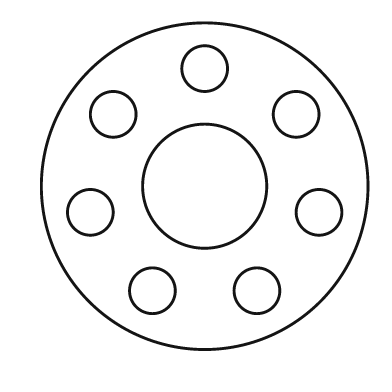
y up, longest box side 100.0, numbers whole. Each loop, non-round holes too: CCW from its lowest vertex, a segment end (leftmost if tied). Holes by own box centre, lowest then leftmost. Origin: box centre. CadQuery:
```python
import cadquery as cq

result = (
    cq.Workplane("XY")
    .moveTo(0.0, 0.0)
    .circle(50.0)
    .moveTo(-16.0, -32.0)
    .circle(7.0)
    .moveTo(16.0, -32.0)
    .circle(7.0)
    .moveTo(-35.0, -8.0)
    .circle(7.0)
    .moveTo(35.0, -8.0)
    .circle(7.0)
    .moveTo(0.0, 0.0)
    .circle(19.0)
    .moveTo(-28.0, 22.0)
    .circle(7.0)
    .moveTo(28.0, 22.0)
    .circle(7.0)
    .moveTo(0.0, 36.0)
    .circle(7.0)
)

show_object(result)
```